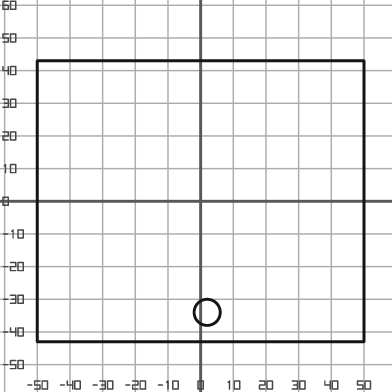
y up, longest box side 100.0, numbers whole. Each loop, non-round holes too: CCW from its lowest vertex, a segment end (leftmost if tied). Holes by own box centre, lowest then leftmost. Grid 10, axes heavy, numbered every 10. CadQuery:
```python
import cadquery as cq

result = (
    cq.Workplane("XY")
    .moveTo(-50.0, -43.0)
    .lineTo(50.0, -43.0)
    .lineTo(50.0, 43.0)
    .lineTo(-50.0, 43.0)
    .close()
    .moveTo(2.0, -34.0)
    .circle(4.0)
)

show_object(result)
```